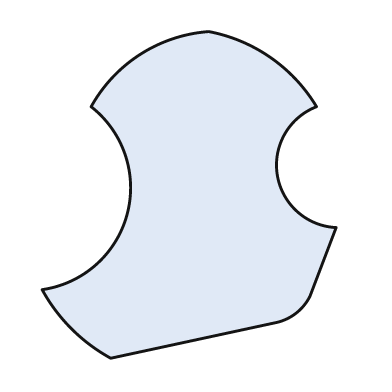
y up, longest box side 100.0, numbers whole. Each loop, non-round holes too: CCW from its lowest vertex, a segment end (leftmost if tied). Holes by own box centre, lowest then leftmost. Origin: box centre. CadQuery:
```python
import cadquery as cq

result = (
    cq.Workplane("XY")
    .moveTo(-24.0, -50.0)
    .lineTo(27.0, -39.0)
    .threePointArc((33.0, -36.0), (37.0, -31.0))
    .lineTo(45.0, -10.0)
    .threePointArc((27.0, 6.0), (39.0, 27.0))
    .threePointArc((25.0, 42.0), (6.0, 50.0))
    .threePointArc((-15.0, 43.0), (-30.0, 27.0))
    .threePointArc((-19.0, -6.0), (-45.0, -29.0))
    .threePointArc((-36.0, -41.0), (-24.0, -50.0))
    .close()
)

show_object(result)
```